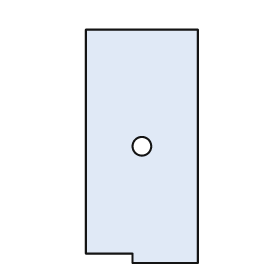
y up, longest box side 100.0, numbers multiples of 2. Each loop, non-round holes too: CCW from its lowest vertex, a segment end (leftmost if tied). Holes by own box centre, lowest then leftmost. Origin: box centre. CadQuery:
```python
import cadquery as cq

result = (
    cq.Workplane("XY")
    .moveTo(-4.0, -50.0)
    .lineTo(24.0, -50.0)
    .lineTo(24.0, 50.0)
    .lineTo(-24.0, 50.0)
    .lineTo(-24.0, -46.0)
    .lineTo(-4.0, -46.0)
    .close()
    .moveTo(0.0, 0.0)
    .circle(4.0)
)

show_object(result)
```